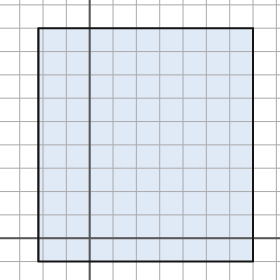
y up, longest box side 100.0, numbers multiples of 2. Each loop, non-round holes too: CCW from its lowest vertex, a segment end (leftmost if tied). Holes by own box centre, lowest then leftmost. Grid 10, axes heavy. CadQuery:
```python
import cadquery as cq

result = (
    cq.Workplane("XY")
    .moveTo(-22.0, -10.0)
    .lineTo(70.0, -10.0)
    .lineTo(70.0, 90.0)
    .lineTo(-22.0, 90.0)
    .close()
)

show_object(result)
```